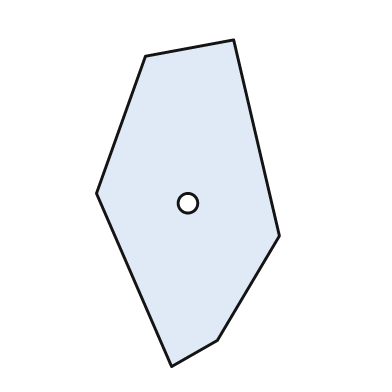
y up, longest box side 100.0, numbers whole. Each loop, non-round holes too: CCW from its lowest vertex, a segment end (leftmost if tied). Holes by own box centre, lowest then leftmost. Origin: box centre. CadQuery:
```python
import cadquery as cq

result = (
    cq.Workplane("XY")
    .moveTo(-5.0, -50.0)
    .lineTo(9.0, -42.0)
    .lineTo(28.0, -10.0)
    .lineTo(14.0, 50.0)
    .lineTo(-13.0, 45.0)
    .lineTo(-28.0, 3.0)
    .close()
    .moveTo(0.0, 0.0)
    .circle(3.0)
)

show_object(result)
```